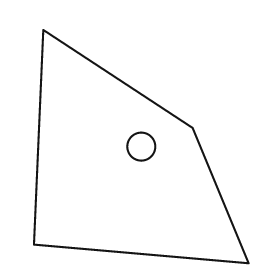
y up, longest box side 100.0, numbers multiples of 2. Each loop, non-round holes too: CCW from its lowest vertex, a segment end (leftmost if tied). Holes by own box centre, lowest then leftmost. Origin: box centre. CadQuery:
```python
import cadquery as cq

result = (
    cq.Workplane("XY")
    .moveTo(46.0, -50.0)
    .lineTo(22.0, 8.0)
    .lineTo(-42.0, 50.0)
    .lineTo(-46.0, -42.0)
    .close()
    .moveTo(0.0, 0.0)
    .circle(6.0)
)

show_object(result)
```